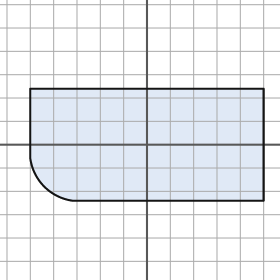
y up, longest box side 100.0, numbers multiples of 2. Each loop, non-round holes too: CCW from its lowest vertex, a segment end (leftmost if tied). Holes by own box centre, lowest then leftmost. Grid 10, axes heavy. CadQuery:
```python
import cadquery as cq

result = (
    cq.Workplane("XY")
    .moveTo(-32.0, -24.0)
    .lineTo(50.0, -24.0)
    .lineTo(50.0, 24.0)
    .lineTo(-50.0, 24.0)
    .lineTo(-50.0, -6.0)
    .threePointArc((-44.0, -18.0), (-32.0, -24.0))
    .close()
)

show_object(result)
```